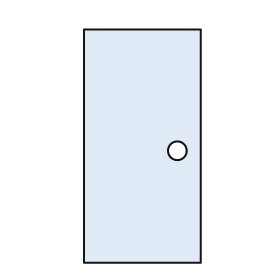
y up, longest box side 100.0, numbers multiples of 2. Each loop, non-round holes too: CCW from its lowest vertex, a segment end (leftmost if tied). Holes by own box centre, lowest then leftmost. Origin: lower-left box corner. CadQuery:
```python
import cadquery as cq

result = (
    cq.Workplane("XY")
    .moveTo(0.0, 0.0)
    .lineTo(50.0, 0.0)
    .lineTo(50.0, 100.0)
    .lineTo(0.0, 100.0)
    .close()
    .moveTo(40.0, 48.0)
    .circle(4.0)
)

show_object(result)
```